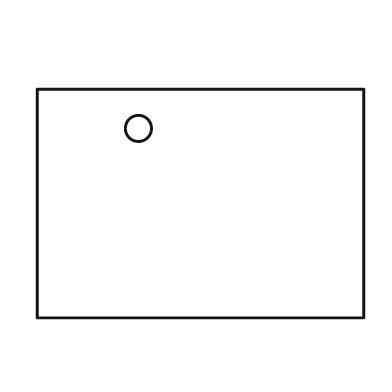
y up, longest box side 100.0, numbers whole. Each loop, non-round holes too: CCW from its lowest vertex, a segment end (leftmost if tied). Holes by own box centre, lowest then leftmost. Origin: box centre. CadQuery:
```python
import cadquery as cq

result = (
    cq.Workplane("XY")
    .moveTo(-50.0, -35.0)
    .lineTo(50.0, -35.0)
    .lineTo(50.0, 35.0)
    .lineTo(-50.0, 35.0)
    .close()
    .moveTo(-19.0, 23.0)
    .circle(4.0)
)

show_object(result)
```